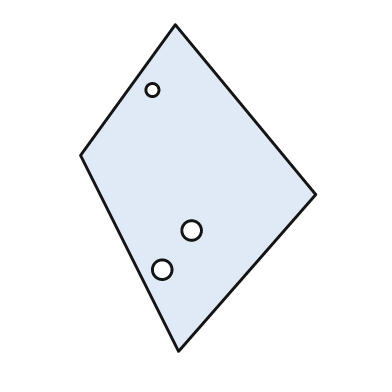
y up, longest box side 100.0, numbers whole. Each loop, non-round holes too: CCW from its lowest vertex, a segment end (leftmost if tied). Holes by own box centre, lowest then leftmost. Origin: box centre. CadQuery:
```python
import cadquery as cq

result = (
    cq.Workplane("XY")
    .moveTo(-6.0, -50.0)
    .lineTo(36.0, -2.0)
    .lineTo(-7.0, 50.0)
    .lineTo(-36.0, 10.0)
    .close()
    .moveTo(-11.0, -25.0)
    .circle(3.0)
    .moveTo(-2.0, -13.0)
    .circle(3.0)
    .moveTo(-14.0, 30.0)
    .circle(2.0)
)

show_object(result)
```